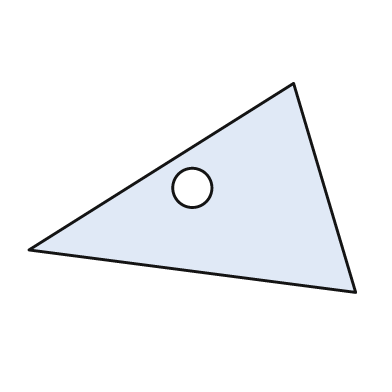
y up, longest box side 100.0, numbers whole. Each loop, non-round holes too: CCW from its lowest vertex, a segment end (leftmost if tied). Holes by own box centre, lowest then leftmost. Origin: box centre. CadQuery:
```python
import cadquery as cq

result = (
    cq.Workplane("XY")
    .moveTo(50.0, -32.0)
    .lineTo(31.0, 32.0)
    .lineTo(-50.0, -19.0)
    .close()
    .moveTo(0.0, 0.0)
    .circle(6.0)
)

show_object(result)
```